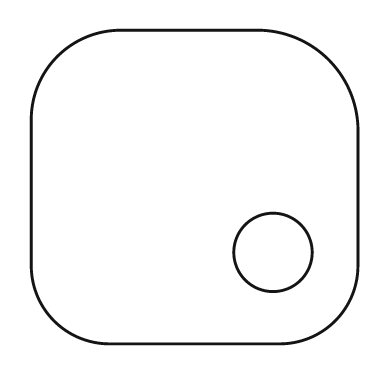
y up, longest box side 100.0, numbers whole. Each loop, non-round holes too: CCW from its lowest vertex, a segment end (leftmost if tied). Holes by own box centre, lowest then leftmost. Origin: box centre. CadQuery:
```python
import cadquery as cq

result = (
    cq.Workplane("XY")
    .moveTo(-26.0, -48.0)
    .lineTo(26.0, -48.0)
    .threePointArc((43.0, -41.0), (50.0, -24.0))
    .lineTo(50.0, 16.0)
    .threePointArc((41.0, 39.0), (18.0, 48.0))
    .lineTo(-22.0, 48.0)
    .threePointArc((-42.0, 40.0), (-50.0, 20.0))
    .lineTo(-50.0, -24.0)
    .threePointArc((-43.0, -41.0), (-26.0, -48.0))
    .close()
    .moveTo(24.0, -20.0)
    .circle(12.0)
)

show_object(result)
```